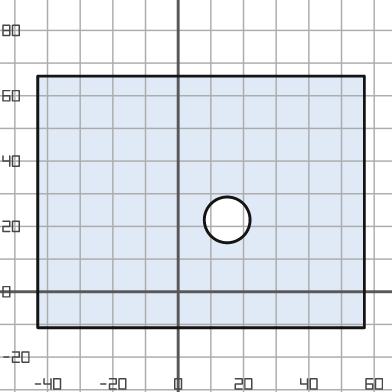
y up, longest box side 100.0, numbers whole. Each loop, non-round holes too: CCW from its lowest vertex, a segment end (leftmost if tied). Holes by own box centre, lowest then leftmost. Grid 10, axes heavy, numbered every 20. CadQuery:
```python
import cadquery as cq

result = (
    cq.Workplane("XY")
    .moveTo(-43.0, -11.0)
    .lineTo(57.0, -11.0)
    .lineTo(57.0, 66.0)
    .lineTo(-43.0, 66.0)
    .close()
    .moveTo(15.0, 22.0)
    .circle(7.0)
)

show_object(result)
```